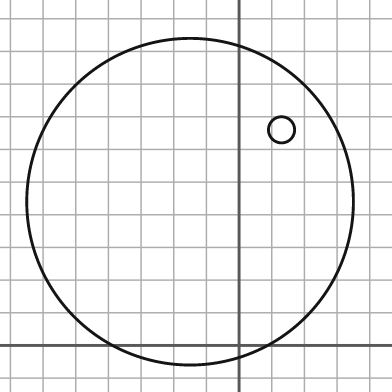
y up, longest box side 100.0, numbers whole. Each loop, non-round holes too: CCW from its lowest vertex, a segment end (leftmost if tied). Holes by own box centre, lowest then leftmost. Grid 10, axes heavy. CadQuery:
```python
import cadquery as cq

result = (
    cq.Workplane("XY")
    .moveTo(-15.0, 44.0)
    .circle(50.0)
    .moveTo(13.0, 66.0)
    .circle(4.0)
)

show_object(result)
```